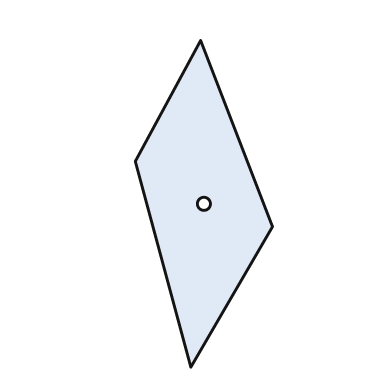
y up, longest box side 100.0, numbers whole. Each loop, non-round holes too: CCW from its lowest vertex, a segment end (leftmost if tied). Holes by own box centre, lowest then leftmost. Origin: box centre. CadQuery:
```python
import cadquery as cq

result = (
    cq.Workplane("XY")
    .moveTo(-4.0, -50.0)
    .lineTo(21.0, -7.0)
    .lineTo(-1.0, 50.0)
    .lineTo(-21.0, 13.0)
    .close()
    .moveTo(0.0, 0.0)
    .circle(2.0)
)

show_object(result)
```